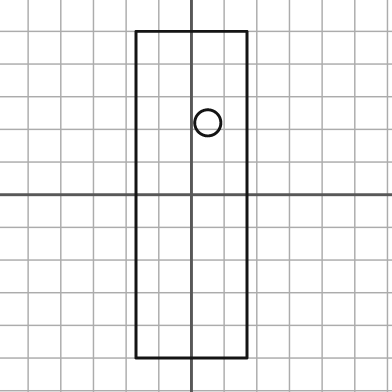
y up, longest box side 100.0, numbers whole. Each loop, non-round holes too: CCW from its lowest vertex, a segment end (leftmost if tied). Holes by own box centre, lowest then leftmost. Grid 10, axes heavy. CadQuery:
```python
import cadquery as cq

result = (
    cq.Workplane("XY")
    .moveTo(-17.0, -50.0)
    .lineTo(17.0, -50.0)
    .lineTo(17.0, 50.0)
    .lineTo(-17.0, 50.0)
    .close()
    .moveTo(5.0, 22.0)
    .circle(4.0)
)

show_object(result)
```